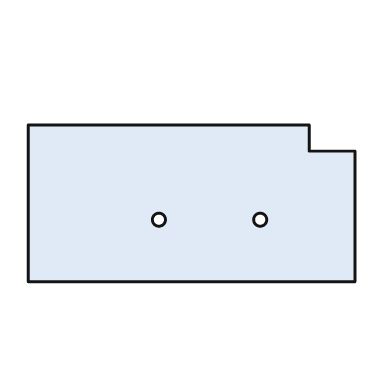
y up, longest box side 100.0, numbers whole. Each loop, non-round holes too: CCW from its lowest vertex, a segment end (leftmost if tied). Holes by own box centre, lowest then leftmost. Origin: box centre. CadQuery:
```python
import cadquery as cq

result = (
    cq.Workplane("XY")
    .moveTo(-50.0, -24.0)
    .lineTo(50.0, -24.0)
    .lineTo(50.0, 16.0)
    .lineTo(36.0, 16.0)
    .lineTo(36.0, 24.0)
    .lineTo(-50.0, 24.0)
    .close()
    .moveTo(-10.0, -5.0)
    .circle(2.0)
    .moveTo(21.0, -5.0)
    .circle(2.0)
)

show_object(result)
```